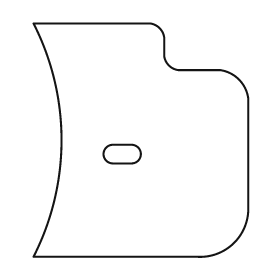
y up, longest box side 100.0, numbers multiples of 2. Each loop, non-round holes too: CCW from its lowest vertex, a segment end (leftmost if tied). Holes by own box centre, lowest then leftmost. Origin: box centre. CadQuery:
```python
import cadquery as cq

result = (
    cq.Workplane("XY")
    .moveTo(-46.0, -50.0)
    .lineTo(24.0, -50.0)
    .threePointArc((40.0, -44.0), (46.0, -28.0))
    .lineTo(46.0, 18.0)
    .threePointArc((42.0, 26.0), (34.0, 30.0))
    .lineTo(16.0, 30.0)
    .threePointArc((12.0, 32.0), (10.0, 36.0))
    .lineTo(10.0, 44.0)
    .threePointArc((8.0, 48.0), (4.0, 50.0))
    .lineTo(-46.0, 50.0)
    .threePointArc((-34.0, 0.0), (-46.0, -50.0))
    .close()
    .moveTo(-12.0, -10.0)
    .lineTo(-4.0, -10.0)
    .threePointArc((0.0, -6.0), (-4.0, -2.0))
    .lineTo(-12.0, -2.0)
    .threePointArc((-16.0, -6.0), (-12.0, -10.0))
    .close()
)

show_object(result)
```